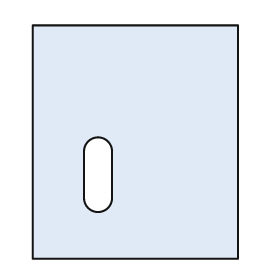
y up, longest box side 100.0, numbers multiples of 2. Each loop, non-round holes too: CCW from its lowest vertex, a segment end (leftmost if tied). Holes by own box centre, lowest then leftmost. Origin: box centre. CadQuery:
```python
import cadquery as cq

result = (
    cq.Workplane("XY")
    .moveTo(-44.0, -50.0)
    .lineTo(44.0, -50.0)
    .lineTo(44.0, 50.0)
    .lineTo(-44.0, 50.0)
    .close()
    .moveTo(-22.0, -24.0)
    .threePointArc((-16.0, -30.0), (-10.0, -24.0))
    .lineTo(-10.0, -4.0)
    .threePointArc((-16.0, 2.0), (-22.0, -4.0))
    .close()
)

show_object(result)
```